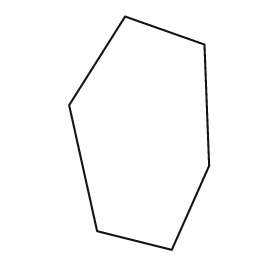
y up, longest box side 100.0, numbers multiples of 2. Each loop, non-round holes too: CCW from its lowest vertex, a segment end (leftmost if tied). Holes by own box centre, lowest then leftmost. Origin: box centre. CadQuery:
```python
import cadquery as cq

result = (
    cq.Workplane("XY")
    .moveTo(14.0, -50.0)
    .lineTo(30.0, -14.0)
    .lineTo(28.0, 38.0)
    .lineTo(-6.0, 50.0)
    .lineTo(-30.0, 12.0)
    .lineTo(-18.0, -42.0)
    .close()
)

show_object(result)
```